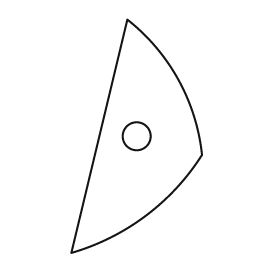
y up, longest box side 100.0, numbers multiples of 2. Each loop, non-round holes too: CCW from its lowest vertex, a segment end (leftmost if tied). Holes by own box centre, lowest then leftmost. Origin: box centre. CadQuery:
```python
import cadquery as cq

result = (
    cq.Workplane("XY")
    .moveTo(-28.0, -50.0)
    .threePointArc((4.0, -34.0), (28.0, -8.0))
    .threePointArc((18.0, 24.0), (-4.0, 50.0))
    .close()
    .moveTo(0.0, 0.0)
    .circle(6.0)
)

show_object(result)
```